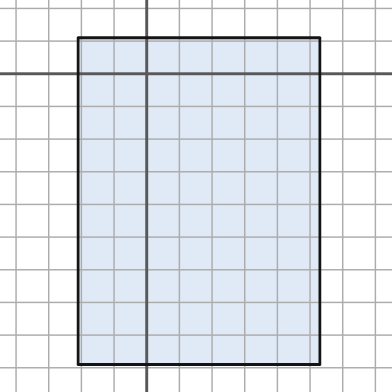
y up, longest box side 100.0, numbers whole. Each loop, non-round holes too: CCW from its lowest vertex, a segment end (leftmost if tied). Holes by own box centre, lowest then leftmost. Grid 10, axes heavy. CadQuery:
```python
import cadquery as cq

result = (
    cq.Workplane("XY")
    .moveTo(-21.0, -89.0)
    .lineTo(53.0, -89.0)
    .lineTo(53.0, 11.0)
    .lineTo(-21.0, 11.0)
    .close()
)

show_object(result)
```